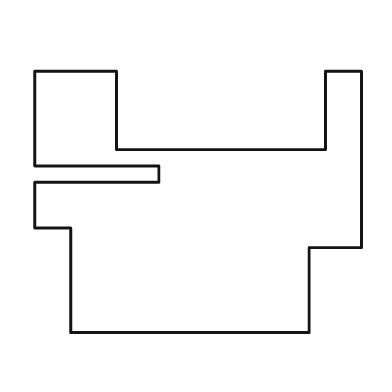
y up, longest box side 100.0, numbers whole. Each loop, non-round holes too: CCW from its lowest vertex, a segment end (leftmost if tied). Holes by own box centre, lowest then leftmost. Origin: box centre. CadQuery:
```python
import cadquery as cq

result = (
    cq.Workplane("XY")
    .moveTo(-39.0, -40.0)
    .lineTo(34.0, -40.0)
    .lineTo(34.0, -14.0)
    .lineTo(50.0, -14.0)
    .lineTo(50.0, 40.0)
    .lineTo(39.0, 40.0)
    .lineTo(39.0, 16.0)
    .lineTo(-25.0, 16.0)
    .lineTo(-25.0, 40.0)
    .lineTo(-50.0, 40.0)
    .lineTo(-50.0, 11.0)
    .lineTo(-12.0, 11.0)
    .lineTo(-12.0, 6.0)
    .lineTo(-50.0, 6.0)
    .lineTo(-50.0, -8.0)
    .lineTo(-39.0, -8.0)
    .close()
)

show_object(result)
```